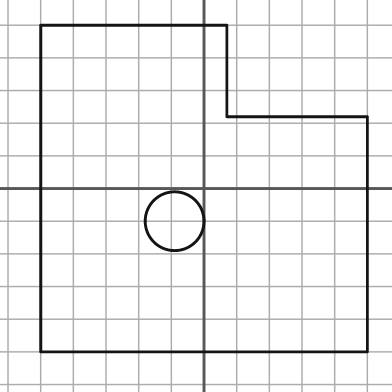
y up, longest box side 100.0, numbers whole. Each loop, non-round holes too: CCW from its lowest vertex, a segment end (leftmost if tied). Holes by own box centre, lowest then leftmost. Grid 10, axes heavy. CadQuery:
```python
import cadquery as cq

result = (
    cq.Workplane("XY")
    .moveTo(-50.0, -50.0)
    .lineTo(50.0, -50.0)
    .lineTo(50.0, 22.0)
    .lineTo(7.0, 22.0)
    .lineTo(7.0, 50.0)
    .lineTo(-50.0, 50.0)
    .close()
    .moveTo(-9.0, -10.0)
    .circle(9.0)
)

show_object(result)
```